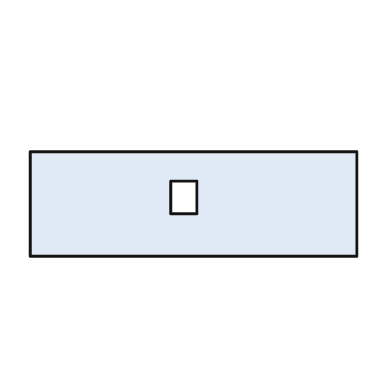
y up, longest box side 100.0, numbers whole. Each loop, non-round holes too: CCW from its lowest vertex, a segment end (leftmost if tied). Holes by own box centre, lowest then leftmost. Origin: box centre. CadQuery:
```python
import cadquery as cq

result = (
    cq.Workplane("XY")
    .moveTo(-50.0, -16.0)
    .lineTo(50.0, -16.0)
    .lineTo(50.0, 16.0)
    .lineTo(-50.0, 16.0)
    .close()
    .moveTo(-7.0, -3.0)
    .lineTo(1.0, -3.0)
    .lineTo(1.0, 7.0)
    .lineTo(-7.0, 7.0)
    .close()
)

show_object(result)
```